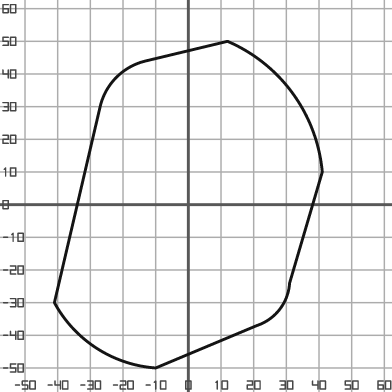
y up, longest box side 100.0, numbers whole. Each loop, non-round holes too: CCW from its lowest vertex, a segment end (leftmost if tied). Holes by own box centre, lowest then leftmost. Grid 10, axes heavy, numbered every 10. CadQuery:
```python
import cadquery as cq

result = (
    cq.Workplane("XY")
    .moveTo(-10.0, -50.0)
    .lineTo(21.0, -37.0)
    .threePointArc((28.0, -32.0), (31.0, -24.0))
    .lineTo(41.0, 10.0)
    .threePointArc((32.0, 34.0), (12.0, 50.0))
    .lineTo(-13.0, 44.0)
    .threePointArc((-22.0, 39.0), (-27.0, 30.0))
    .lineTo(-41.0, -30.0)
    .threePointArc((-28.0, -44.0), (-10.0, -50.0))
    .close()
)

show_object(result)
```